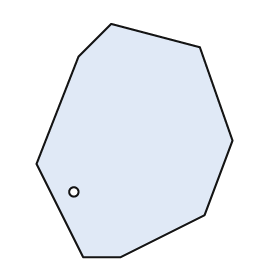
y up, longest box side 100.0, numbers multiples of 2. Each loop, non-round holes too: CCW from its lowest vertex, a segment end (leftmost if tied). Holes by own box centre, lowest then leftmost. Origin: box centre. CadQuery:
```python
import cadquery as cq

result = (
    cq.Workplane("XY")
    .moveTo(-22.0, -50.0)
    .lineTo(-6.0, -50.0)
    .lineTo(30.0, -32.0)
    .lineTo(42.0, 0.0)
    .lineTo(28.0, 40.0)
    .lineTo(-10.0, 50.0)
    .lineTo(-24.0, 36.0)
    .lineTo(-42.0, -10.0)
    .close()
    .moveTo(-26.0, -22.0)
    .circle(2.0)
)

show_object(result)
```